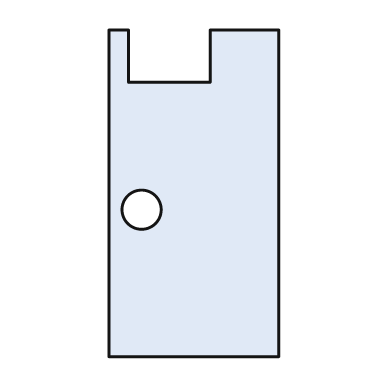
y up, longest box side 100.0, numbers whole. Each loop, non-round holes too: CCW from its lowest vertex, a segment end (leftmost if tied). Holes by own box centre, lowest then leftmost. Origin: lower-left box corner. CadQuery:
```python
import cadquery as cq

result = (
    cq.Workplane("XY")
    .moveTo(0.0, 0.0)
    .lineTo(52.0, 0.0)
    .lineTo(52.0, 100.0)
    .lineTo(31.0, 100.0)
    .lineTo(31.0, 84.0)
    .lineTo(6.0, 84.0)
    .lineTo(6.0, 100.0)
    .lineTo(0.0, 100.0)
    .close()
    .moveTo(10.0, 45.0)
    .circle(6.0)
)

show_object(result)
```